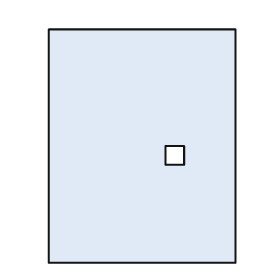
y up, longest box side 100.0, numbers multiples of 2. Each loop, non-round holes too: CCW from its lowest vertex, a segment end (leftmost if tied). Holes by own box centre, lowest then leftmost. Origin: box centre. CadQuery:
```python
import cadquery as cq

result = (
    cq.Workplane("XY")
    .moveTo(-40.0, -50.0)
    .lineTo(40.0, -50.0)
    .lineTo(40.0, 50.0)
    .lineTo(-40.0, 50.0)
    .close()
    .moveTo(10.0, -8.0)
    .lineTo(18.0, -8.0)
    .lineTo(18.0, 0.0)
    .lineTo(10.0, 0.0)
    .close()
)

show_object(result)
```